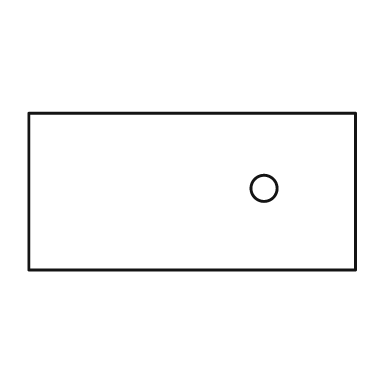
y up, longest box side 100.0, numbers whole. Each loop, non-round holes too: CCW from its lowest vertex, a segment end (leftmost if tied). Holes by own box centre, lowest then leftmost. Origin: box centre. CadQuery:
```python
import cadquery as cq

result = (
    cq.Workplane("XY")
    .moveTo(-50.0, -24.0)
    .lineTo(50.0, -24.0)
    .lineTo(50.0, 24.0)
    .lineTo(-50.0, 24.0)
    .close()
    .moveTo(22.0, 1.0)
    .circle(4.0)
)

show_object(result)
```